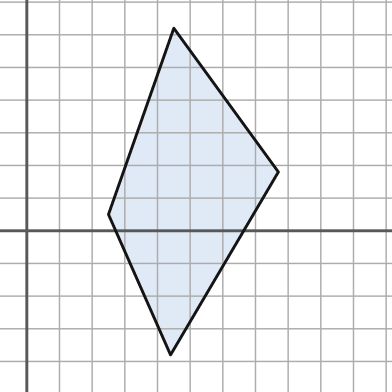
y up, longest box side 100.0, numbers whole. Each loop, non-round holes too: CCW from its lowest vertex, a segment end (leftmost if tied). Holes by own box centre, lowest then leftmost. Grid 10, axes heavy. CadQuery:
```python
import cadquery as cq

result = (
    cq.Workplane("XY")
    .moveTo(44.0, -38.0)
    .lineTo(77.0, 18.0)
    .lineTo(45.0, 62.0)
    .lineTo(25.0, 5.0)
    .close()
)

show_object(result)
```